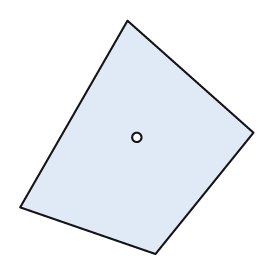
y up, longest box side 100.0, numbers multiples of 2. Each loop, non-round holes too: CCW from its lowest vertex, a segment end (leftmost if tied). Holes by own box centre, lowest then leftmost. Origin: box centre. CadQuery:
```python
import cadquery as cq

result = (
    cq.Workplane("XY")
    .moveTo(8.0, -50.0)
    .lineTo(50.0, 2.0)
    .lineTo(-4.0, 50.0)
    .lineTo(-50.0, -30.0)
    .close()
    .moveTo(0.0, 0.0)
    .circle(2.0)
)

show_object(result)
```